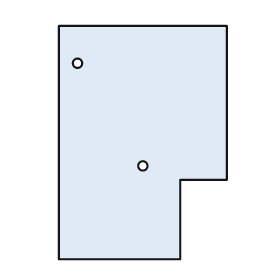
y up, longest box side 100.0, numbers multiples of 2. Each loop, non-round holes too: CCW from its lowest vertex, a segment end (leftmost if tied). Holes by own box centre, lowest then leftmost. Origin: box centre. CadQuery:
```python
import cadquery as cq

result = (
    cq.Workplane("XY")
    .moveTo(-36.0, -50.0)
    .lineTo(16.0, -50.0)
    .lineTo(16.0, -16.0)
    .lineTo(36.0, -16.0)
    .lineTo(36.0, 50.0)
    .lineTo(-36.0, 50.0)
    .close()
    .moveTo(0.0, -10.0)
    .circle(2.0)
    .moveTo(-28.0, 34.0)
    .circle(2.0)
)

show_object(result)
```